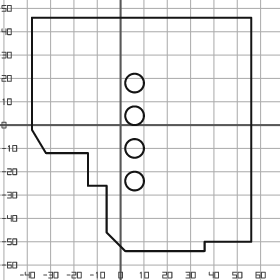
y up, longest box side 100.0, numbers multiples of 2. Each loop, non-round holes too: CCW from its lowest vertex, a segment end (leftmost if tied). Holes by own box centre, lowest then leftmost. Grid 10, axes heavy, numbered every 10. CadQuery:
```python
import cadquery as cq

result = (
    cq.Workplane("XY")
    .moveTo(2.0, -54.0)
    .lineTo(36.0, -54.0)
    .lineTo(36.0, -50.0)
    .lineTo(56.0, -50.0)
    .lineTo(56.0, 46.0)
    .lineTo(-38.0, 46.0)
    .lineTo(-38.0, -2.0)
    .lineTo(-32.0, -12.0)
    .lineTo(-14.0, -12.0)
    .lineTo(-14.0, -26.0)
    .lineTo(-6.0, -26.0)
    .lineTo(-6.0, -46.0)
    .close()
    .moveTo(6.0, -24.0)
    .circle(4.0)
    .moveTo(6.0, -10.0)
    .circle(4.0)
    .moveTo(6.0, 4.0)
    .circle(4.0)
    .moveTo(6.0, 18.0)
    .circle(4.0)
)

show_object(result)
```